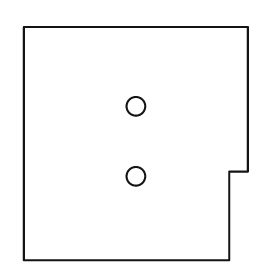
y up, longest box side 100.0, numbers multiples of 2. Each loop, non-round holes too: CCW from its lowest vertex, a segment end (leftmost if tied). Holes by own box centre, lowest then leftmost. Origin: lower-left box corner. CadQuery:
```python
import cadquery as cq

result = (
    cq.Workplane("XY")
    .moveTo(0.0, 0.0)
    .lineTo(88.0, 0.0)
    .lineTo(88.0, 38.0)
    .lineTo(96.0, 38.0)
    .lineTo(96.0, 100.0)
    .lineTo(0.0, 100.0)
    .close()
    .moveTo(48.0, 36.0)
    .circle(4.0)
    .moveTo(48.0, 66.0)
    .circle(4.0)
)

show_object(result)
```